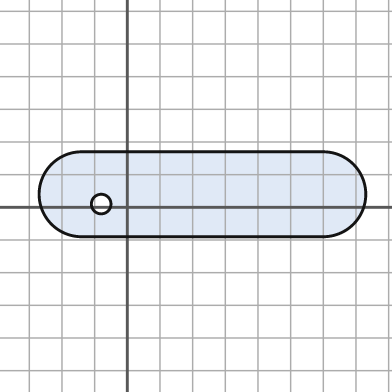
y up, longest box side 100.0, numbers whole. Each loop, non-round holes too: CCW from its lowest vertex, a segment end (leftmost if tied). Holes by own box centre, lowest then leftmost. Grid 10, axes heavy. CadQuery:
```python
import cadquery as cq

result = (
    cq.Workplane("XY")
    .moveTo(-14.0, -9.0)
    .lineTo(60.0, -9.0)
    .threePointArc((73.0, 4.0), (60.0, 17.0))
    .lineTo(-14.0, 17.0)
    .threePointArc((-27.0, 4.0), (-14.0, -9.0))
    .close()
    .moveTo(-8.0, 1.0)
    .circle(3.0)
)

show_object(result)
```